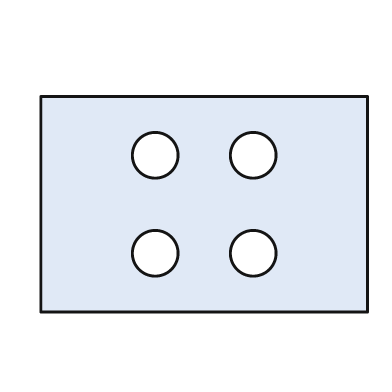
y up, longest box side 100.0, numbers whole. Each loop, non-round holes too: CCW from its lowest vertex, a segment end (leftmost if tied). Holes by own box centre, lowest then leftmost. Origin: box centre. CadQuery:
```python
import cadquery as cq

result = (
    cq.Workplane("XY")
    .moveTo(-50.0, -33.0)
    .lineTo(50.0, -33.0)
    .lineTo(50.0, 33.0)
    .lineTo(-50.0, 33.0)
    .close()
    .moveTo(-15.0, -15.0)
    .circle(7.0)
    .moveTo(15.0, -15.0)
    .circle(7.0)
    .moveTo(-15.0, 15.0)
    .circle(7.0)
    .moveTo(15.0, 15.0)
    .circle(7.0)
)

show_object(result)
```